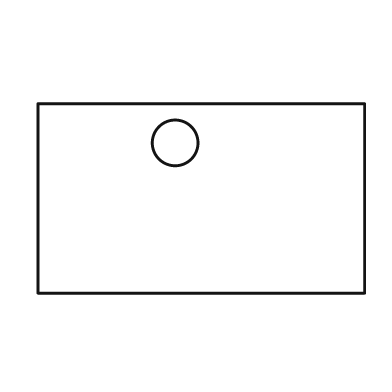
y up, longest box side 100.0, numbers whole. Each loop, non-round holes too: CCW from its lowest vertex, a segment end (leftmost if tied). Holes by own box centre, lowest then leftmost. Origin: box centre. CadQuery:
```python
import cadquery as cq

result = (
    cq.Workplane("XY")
    .moveTo(-50.0, -29.0)
    .lineTo(50.0, -29.0)
    .lineTo(50.0, 29.0)
    .lineTo(-50.0, 29.0)
    .close()
    .moveTo(-8.0, 17.0)
    .circle(7.0)
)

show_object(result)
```